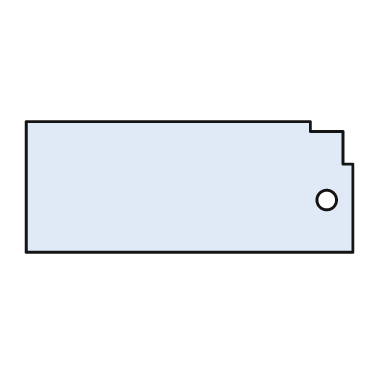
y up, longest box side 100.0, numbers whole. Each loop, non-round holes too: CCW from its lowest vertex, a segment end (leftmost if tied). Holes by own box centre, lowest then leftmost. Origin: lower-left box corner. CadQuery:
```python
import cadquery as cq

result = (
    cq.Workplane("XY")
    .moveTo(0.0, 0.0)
    .lineTo(100.0, 0.0)
    .lineTo(100.0, 27.0)
    .lineTo(97.0, 27.0)
    .lineTo(97.0, 37.0)
    .lineTo(87.0, 37.0)
    .lineTo(87.0, 40.0)
    .lineTo(0.0, 40.0)
    .close()
    .moveTo(92.0, 16.0)
    .circle(3.0)
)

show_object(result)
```